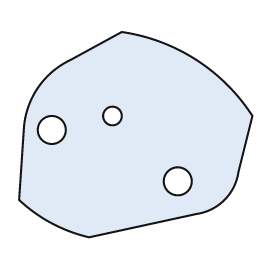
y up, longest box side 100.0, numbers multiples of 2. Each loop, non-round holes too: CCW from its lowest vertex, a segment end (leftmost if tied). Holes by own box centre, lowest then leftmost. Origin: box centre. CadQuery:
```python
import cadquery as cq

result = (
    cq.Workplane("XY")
    .moveTo(-20.0, -44.0)
    .lineTo(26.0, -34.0)
    .threePointArc((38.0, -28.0), (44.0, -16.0))
    .lineTo(50.0, 8.0)
    .threePointArc((26.0, 32.0), (-6.0, 44.0))
    .lineTo(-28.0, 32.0)
    .threePointArc((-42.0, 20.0), (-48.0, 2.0))
    .lineTo(-50.0, -28.0)
    .threePointArc((-36.0, -38.0), (-20.0, -44.0))
    .close()
    .moveTo(18.0, -20.0)
    .circle(6.0)
    .moveTo(-36.0, 2.0)
    .circle(6.0)
    .moveTo(-10.0, 8.0)
    .circle(4.0)
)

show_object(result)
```